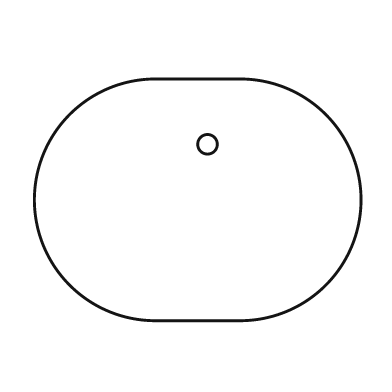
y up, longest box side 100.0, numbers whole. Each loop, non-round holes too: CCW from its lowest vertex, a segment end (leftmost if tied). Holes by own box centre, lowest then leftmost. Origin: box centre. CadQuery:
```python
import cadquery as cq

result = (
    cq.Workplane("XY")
    .moveTo(-13.0, -37.0)
    .lineTo(13.0, -37.0)
    .threePointArc((50.0, 0.0), (13.0, 37.0))
    .lineTo(-13.0, 37.0)
    .threePointArc((-50.0, 0.0), (-13.0, -37.0))
    .close()
    .moveTo(3.0, 17.0)
    .circle(3.0)
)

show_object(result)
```